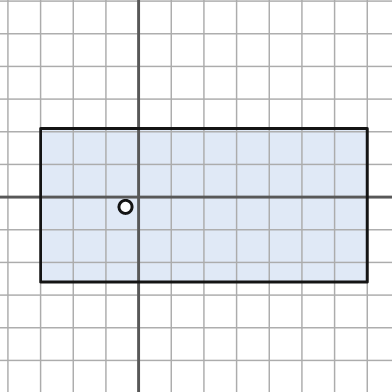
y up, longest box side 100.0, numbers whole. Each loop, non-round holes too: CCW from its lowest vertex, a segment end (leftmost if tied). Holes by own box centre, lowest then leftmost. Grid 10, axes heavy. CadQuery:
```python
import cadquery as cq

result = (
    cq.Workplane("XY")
    .moveTo(-30.0, -26.0)
    .lineTo(70.0, -26.0)
    .lineTo(70.0, 21.0)
    .lineTo(-30.0, 21.0)
    .close()
    .moveTo(-4.0, -3.0)
    .circle(2.0)
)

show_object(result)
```